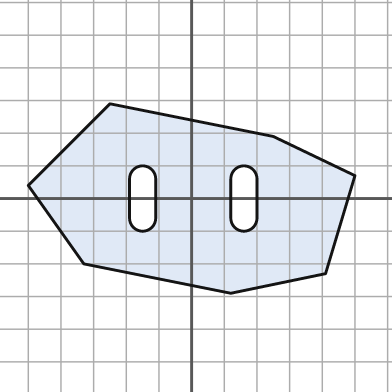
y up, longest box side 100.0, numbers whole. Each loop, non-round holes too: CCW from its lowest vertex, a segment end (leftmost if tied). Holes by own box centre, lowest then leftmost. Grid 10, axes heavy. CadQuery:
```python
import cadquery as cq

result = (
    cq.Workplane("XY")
    .moveTo(12.0, -29.0)
    .lineTo(41.0, -23.0)
    .lineTo(50.0, 7.0)
    .lineTo(25.0, 19.0)
    .lineTo(-25.0, 29.0)
    .lineTo(-50.0, 4.0)
    .lineTo(-33.0, -20.0)
    .close()
    .moveTo(-19.0, -6.0)
    .threePointArc((-15.0, -10.0), (-11.0, -6.0))
    .lineTo(-11.0, 6.0)
    .threePointArc((-15.0, 10.0), (-19.0, 6.0))
    .close()
    .moveTo(12.0, -6.0)
    .threePointArc((16.0, -10.0), (20.0, -6.0))
    .lineTo(20.0, 6.0)
    .threePointArc((16.0, 10.0), (12.0, 6.0))
    .close()
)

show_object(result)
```